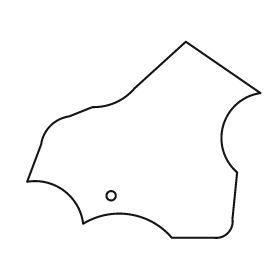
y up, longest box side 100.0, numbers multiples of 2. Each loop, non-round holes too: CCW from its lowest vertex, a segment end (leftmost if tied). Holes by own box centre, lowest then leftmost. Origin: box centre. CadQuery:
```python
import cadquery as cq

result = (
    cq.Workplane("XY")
    .moveTo(12.0, -42.0)
    .lineTo(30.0, -42.0)
    .threePointArc((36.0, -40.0), (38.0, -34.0))
    .lineTo(40.0, -14.0)
    .threePointArc((34.0, 6.0), (50.0, 20.0))
    .lineTo(18.0, 42.0)
    .lineTo(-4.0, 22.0)
    .threePointArc((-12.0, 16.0), (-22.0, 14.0))
    .lineTo(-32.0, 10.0)
    .threePointArc((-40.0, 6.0), (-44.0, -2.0))
    .lineTo(-50.0, -18.0)
    .threePointArc((-34.0, -22.0), (-26.0, -36.0))
    .threePointArc((-6.0, -32.0), (12.0, -42.0))
    .close()
    .moveTo(-14.0, -24.0)
    .circle(2.0)
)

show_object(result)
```